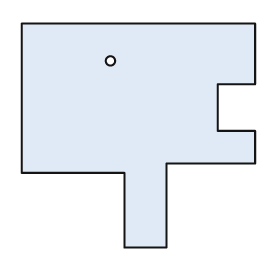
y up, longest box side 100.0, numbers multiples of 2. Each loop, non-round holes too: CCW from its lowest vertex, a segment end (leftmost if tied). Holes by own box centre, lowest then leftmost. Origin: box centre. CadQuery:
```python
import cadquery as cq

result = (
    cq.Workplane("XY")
    .moveTo(-6.0, -48.0)
    .lineTo(12.0, -48.0)
    .lineTo(12.0, -12.0)
    .lineTo(50.0, -12.0)
    .lineTo(50.0, 2.0)
    .lineTo(34.0, 2.0)
    .lineTo(34.0, 22.0)
    .lineTo(50.0, 22.0)
    .lineTo(50.0, 48.0)
    .lineTo(-50.0, 48.0)
    .lineTo(-50.0, -16.0)
    .lineTo(-6.0, -16.0)
    .close()
    .moveTo(-12.0, 32.0)
    .circle(2.0)
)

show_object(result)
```